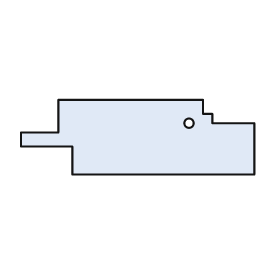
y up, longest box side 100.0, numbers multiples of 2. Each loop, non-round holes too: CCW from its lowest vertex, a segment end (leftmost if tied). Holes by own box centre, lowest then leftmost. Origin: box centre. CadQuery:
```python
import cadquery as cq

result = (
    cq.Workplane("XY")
    .moveTo(-28.0, -16.0)
    .lineTo(50.0, -16.0)
    .lineTo(50.0, 6.0)
    .lineTo(32.0, 6.0)
    .lineTo(32.0, 10.0)
    .lineTo(28.0, 10.0)
    .lineTo(28.0, 16.0)
    .lineTo(-34.0, 16.0)
    .lineTo(-34.0, 2.0)
    .lineTo(-50.0, 2.0)
    .lineTo(-50.0, -4.0)
    .lineTo(-28.0, -4.0)
    .close()
    .moveTo(22.0, 6.0)
    .circle(2.0)
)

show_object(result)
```